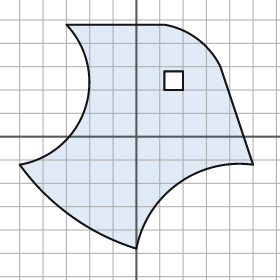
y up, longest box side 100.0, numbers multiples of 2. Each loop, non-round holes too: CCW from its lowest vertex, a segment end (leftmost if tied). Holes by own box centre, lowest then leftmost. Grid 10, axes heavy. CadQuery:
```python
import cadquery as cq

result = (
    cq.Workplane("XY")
    .moveTo(0.0, -48.0)
    .threePointArc((18.0, -20.0), (50.0, -12.0))
    .lineTo(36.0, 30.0)
    .threePointArc((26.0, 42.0), (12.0, 48.0))
    .lineTo(-30.0, 48.0)
    .threePointArc((-22.0, 12.0), (-50.0, -12.0))
    .threePointArc((-28.0, -34.0), (0.0, -48.0))
    .close()
    .moveTo(12.0, 20.0)
    .lineTo(20.0, 20.0)
    .lineTo(20.0, 28.0)
    .lineTo(12.0, 28.0)
    .close()
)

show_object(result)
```